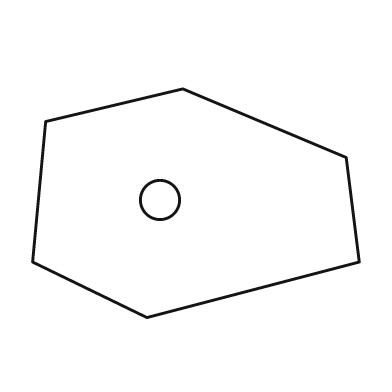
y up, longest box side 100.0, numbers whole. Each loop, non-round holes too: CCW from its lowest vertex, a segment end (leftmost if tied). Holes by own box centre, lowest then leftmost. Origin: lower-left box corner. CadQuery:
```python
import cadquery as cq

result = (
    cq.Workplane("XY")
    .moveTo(35.0, 0.0)
    .lineTo(100.0, 17.0)
    .lineTo(96.0, 49.0)
    .lineTo(46.0, 70.0)
    .lineTo(4.0, 60.0)
    .lineTo(0.0, 17.0)
    .close()
    .moveTo(39.0, 36.0)
    .circle(6.0)
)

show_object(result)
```